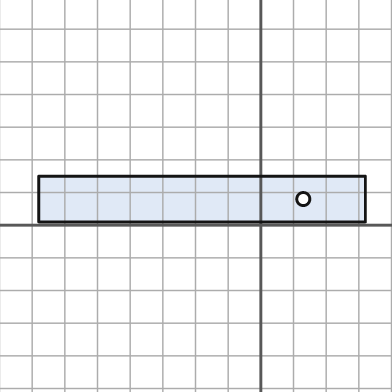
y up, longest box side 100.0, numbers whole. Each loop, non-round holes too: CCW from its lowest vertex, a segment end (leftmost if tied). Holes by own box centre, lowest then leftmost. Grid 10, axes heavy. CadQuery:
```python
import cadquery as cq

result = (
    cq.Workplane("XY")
    .moveTo(-68.0, 1.0)
    .lineTo(32.0, 1.0)
    .lineTo(32.0, 15.0)
    .lineTo(-68.0, 15.0)
    .close()
    .moveTo(13.0, 8.0)
    .circle(2.0)
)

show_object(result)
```